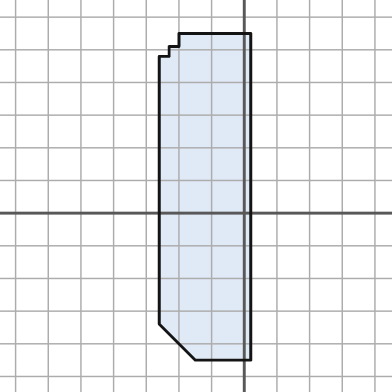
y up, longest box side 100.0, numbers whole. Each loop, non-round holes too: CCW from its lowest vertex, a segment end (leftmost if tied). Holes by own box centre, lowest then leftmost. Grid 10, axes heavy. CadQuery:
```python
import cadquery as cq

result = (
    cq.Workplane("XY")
    .moveTo(-15.0, -45.0)
    .lineTo(2.0, -45.0)
    .lineTo(2.0, 55.0)
    .lineTo(-20.0, 55.0)
    .lineTo(-20.0, 51.0)
    .lineTo(-23.0, 51.0)
    .lineTo(-23.0, 48.0)
    .lineTo(-26.0, 48.0)
    .lineTo(-26.0, -34.0)
    .close()
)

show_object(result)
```